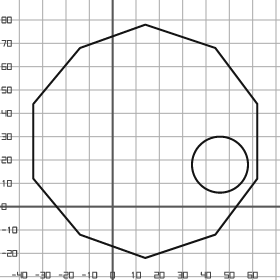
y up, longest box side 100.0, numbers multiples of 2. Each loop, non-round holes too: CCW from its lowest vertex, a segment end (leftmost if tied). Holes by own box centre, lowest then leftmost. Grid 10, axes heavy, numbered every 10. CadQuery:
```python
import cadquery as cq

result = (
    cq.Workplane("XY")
    .moveTo(14.0, -22.0)
    .lineTo(44.0, -12.0)
    .lineTo(62.0, 12.0)
    .lineTo(62.0, 44.0)
    .lineTo(44.0, 68.0)
    .lineTo(14.0, 78.0)
    .lineTo(-14.0, 68.0)
    .lineTo(-34.0, 44.0)
    .lineTo(-34.0, 12.0)
    .lineTo(-14.0, -12.0)
    .close()
    .moveTo(46.0, 18.0)
    .circle(12.0)
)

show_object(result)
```